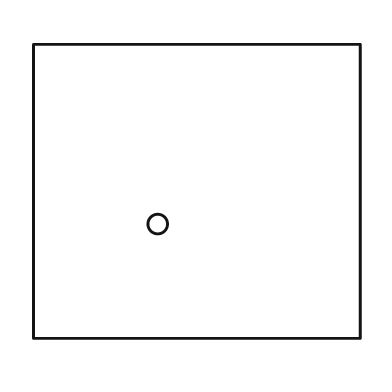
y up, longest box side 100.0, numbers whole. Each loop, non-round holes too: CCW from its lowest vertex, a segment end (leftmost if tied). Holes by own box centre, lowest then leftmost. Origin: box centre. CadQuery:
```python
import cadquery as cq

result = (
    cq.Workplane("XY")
    .moveTo(-50.0, -45.0)
    .lineTo(50.0, -45.0)
    .lineTo(50.0, 45.0)
    .lineTo(-50.0, 45.0)
    .close()
    .moveTo(-12.0, -10.0)
    .circle(3.0)
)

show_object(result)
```